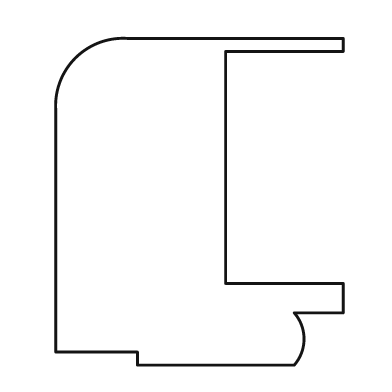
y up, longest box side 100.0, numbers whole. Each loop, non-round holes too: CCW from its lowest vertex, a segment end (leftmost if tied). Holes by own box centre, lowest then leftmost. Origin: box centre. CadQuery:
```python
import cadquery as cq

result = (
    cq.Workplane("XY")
    .moveTo(-19.0, -50.0)
    .lineTo(29.0, -50.0)
    .threePointArc((32.0, -42.0), (29.0, -34.0))
    .lineTo(44.0, -34.0)
    .lineTo(44.0, -25.0)
    .lineTo(8.0, -25.0)
    .lineTo(8.0, 46.0)
    .lineTo(44.0, 46.0)
    .lineTo(44.0, 50.0)
    .lineTo(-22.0, 50.0)
    .threePointArc((-38.0, 44.0), (-44.0, 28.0))
    .lineTo(-44.0, -46.0)
    .lineTo(-19.0, -46.0)
    .close()
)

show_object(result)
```